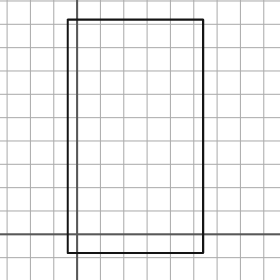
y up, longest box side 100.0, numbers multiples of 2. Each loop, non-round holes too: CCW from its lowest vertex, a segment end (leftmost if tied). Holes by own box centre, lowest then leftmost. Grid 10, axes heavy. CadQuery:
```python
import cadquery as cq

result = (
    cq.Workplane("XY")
    .moveTo(-4.0, -8.0)
    .lineTo(54.0, -8.0)
    .lineTo(54.0, 92.0)
    .lineTo(-4.0, 92.0)
    .close()
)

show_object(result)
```